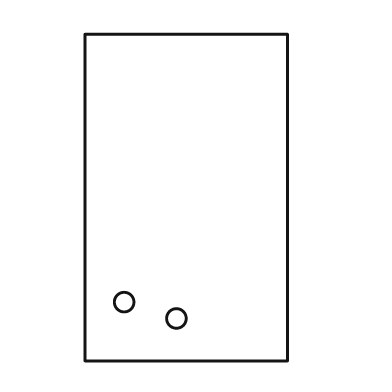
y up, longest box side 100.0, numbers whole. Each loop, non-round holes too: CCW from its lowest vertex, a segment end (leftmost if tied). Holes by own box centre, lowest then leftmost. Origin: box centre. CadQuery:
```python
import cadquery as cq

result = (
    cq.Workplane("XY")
    .moveTo(-31.0, -50.0)
    .lineTo(31.0, -50.0)
    .lineTo(31.0, 50.0)
    .lineTo(-31.0, 50.0)
    .close()
    .moveTo(-3.0, -37.0)
    .circle(3.0)
    .moveTo(-19.0, -32.0)
    .circle(3.0)
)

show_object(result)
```